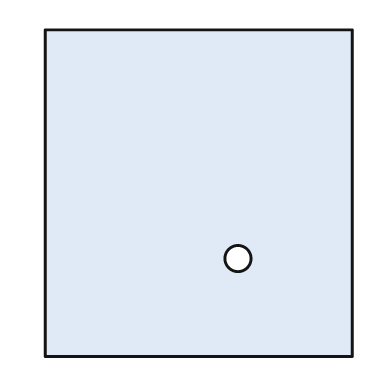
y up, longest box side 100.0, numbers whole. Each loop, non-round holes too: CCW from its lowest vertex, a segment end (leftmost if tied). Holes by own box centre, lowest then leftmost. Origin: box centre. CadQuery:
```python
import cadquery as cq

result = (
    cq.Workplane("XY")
    .moveTo(-47.0, -50.0)
    .lineTo(47.0, -50.0)
    .lineTo(47.0, 50.0)
    .lineTo(-47.0, 50.0)
    .close()
    .moveTo(12.0, -20.0)
    .circle(4.0)
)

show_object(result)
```